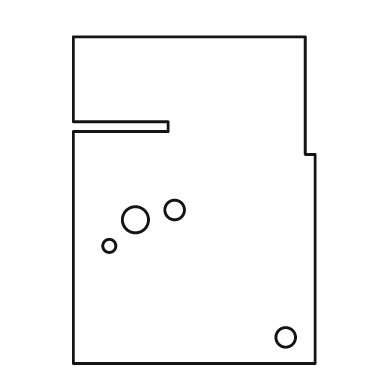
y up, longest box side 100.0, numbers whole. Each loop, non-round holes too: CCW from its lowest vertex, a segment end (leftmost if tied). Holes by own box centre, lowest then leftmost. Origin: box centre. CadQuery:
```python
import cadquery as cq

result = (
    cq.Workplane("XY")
    .moveTo(-37.0, -50.0)
    .lineTo(37.0, -50.0)
    .lineTo(37.0, 14.0)
    .lineTo(34.0, 14.0)
    .lineTo(34.0, 50.0)
    .lineTo(-37.0, 50.0)
    .lineTo(-37.0, 24.0)
    .lineTo(-8.0, 24.0)
    .lineTo(-8.0, 21.0)
    .lineTo(-37.0, 21.0)
    .close()
    .moveTo(28.0, -42.0)
    .circle(3.0)
    .moveTo(-26.0, -14.0)
    .circle(2.0)
    .moveTo(-18.0, -6.0)
    .circle(4.0)
    .moveTo(-6.0, -3.0)
    .circle(3.0)
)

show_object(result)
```